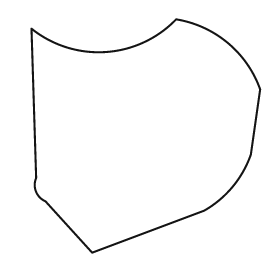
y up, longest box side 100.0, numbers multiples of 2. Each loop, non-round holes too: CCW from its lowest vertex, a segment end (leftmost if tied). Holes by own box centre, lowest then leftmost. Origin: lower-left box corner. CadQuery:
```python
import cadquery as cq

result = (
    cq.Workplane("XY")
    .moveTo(26.0, 0.0)
    .lineTo(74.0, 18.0)
    .threePointArc((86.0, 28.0), (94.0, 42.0))
    .lineTo(98.0, 70.0)
    .threePointArc((84.0, 90.0), (62.0, 100.0))
    .threePointArc((32.0, 86.0), (0.0, 96.0))
    .lineTo(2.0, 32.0)
    .threePointArc((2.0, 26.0), (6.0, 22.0))
    .close()
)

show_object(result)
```